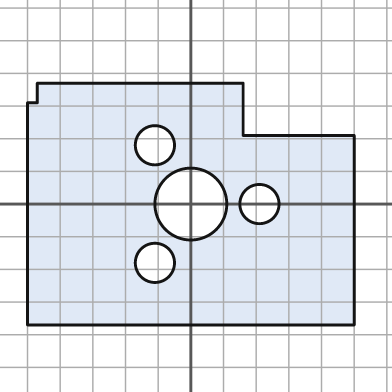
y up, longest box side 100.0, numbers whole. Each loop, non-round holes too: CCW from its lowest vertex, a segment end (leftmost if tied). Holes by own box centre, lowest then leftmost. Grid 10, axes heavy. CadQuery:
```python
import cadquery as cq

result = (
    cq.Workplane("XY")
    .moveTo(-50.0, -37.0)
    .lineTo(50.0, -37.0)
    .lineTo(50.0, 21.0)
    .lineTo(16.0, 21.0)
    .lineTo(16.0, 37.0)
    .lineTo(-47.0, 37.0)
    .lineTo(-47.0, 31.0)
    .lineTo(-50.0, 31.0)
    .close()
    .moveTo(-11.0, -18.0)
    .circle(6.0)
    .moveTo(0.0, 0.0)
    .circle(11.0)
    .moveTo(21.0, 0.0)
    .circle(6.0)
    .moveTo(-11.0, 18.0)
    .circle(6.0)
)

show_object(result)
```